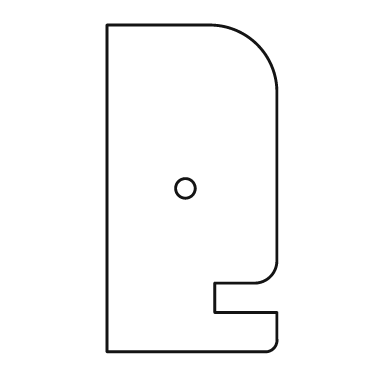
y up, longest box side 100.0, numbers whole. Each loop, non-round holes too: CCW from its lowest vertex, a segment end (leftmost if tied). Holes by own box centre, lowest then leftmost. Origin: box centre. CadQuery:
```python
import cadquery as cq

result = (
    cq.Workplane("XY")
    .moveTo(-26.0, -50.0)
    .lineTo(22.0, -50.0)
    .threePointArc((25.0, -49.0), (26.0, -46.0))
    .lineTo(26.0, -38.0)
    .lineTo(7.0, -38.0)
    .lineTo(7.0, -29.0)
    .lineTo(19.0, -29.0)
    .threePointArc((24.0, -27.0), (26.0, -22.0))
    .lineTo(26.0, 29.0)
    .threePointArc((20.0, 44.0), (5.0, 50.0))
    .lineTo(-26.0, 50.0)
    .close()
    .moveTo(-2.0, 0.0)
    .circle(3.0)
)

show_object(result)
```